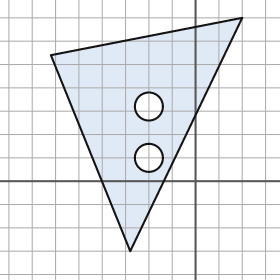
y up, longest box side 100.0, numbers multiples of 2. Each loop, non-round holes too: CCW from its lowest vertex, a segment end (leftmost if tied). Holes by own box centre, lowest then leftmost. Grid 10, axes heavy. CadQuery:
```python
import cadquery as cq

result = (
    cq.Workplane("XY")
    .moveTo(-28.0, -30.0)
    .lineTo(20.0, 70.0)
    .lineTo(-62.0, 54.0)
    .close()
    .moveTo(-20.0, 10.0)
    .circle(6.0)
    .moveTo(-20.0, 32.0)
    .circle(6.0)
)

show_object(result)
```